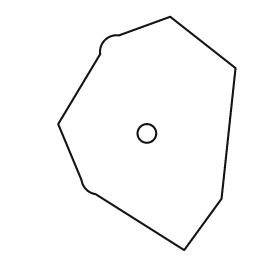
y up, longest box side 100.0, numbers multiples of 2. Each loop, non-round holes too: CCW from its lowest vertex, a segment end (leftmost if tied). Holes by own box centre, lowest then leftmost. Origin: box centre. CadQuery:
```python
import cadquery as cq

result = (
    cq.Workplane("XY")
    .moveTo(16.0, -50.0)
    .lineTo(32.0, -28.0)
    .lineTo(38.0, 28.0)
    .lineTo(10.0, 50.0)
    .lineTo(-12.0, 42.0)
    .threePointArc((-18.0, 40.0), (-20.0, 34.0))
    .lineTo(-38.0, 4.0)
    .lineTo(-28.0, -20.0)
    .threePointArc((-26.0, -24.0), (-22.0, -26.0))
    .close()
    .moveTo(0.0, 0.0)
    .circle(4.0)
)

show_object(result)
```